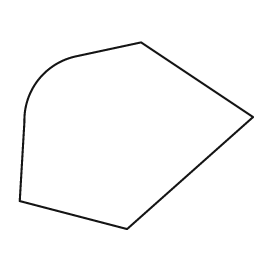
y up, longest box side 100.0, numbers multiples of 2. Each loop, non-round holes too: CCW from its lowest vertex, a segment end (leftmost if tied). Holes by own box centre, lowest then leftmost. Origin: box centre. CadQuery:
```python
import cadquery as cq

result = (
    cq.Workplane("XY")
    .moveTo(-4.0, -40.0)
    .lineTo(50.0, 8.0)
    .lineTo(2.0, 40.0)
    .lineTo(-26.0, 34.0)
    .threePointArc((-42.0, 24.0), (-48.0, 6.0))
    .lineTo(-50.0, -28.0)
    .close()
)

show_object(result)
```